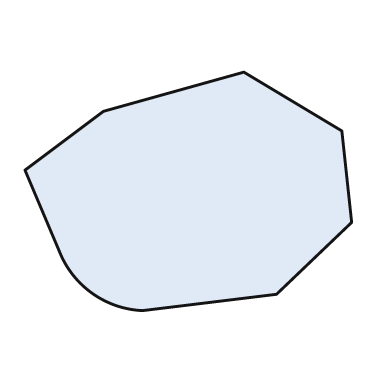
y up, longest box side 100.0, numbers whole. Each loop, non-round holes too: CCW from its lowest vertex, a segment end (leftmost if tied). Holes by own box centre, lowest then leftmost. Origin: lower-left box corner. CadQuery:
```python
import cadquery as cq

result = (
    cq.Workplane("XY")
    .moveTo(36.0, 0.0)
    .lineTo(77.0, 5.0)
    .lineTo(100.0, 27.0)
    .lineTo(97.0, 55.0)
    .lineTo(67.0, 73.0)
    .lineTo(24.0, 61.0)
    .lineTo(0.0, 43.0)
    .lineTo(11.0, 17.0)
    .threePointArc((21.0, 5.0), (36.0, 0.0))
    .close()
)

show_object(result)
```